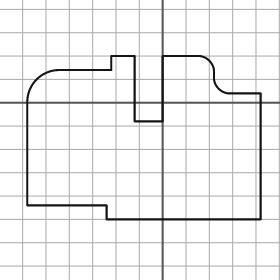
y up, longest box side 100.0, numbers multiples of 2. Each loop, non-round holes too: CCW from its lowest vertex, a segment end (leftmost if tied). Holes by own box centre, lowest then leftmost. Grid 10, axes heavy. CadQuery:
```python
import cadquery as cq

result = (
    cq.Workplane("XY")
    .moveTo(-24.0, -50.0)
    .lineTo(42.0, -50.0)
    .lineTo(42.0, 4.0)
    .lineTo(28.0, 4.0)
    .threePointArc((24.0, 6.0), (22.0, 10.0))
    .lineTo(22.0, 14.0)
    .threePointArc((20.0, 18.0), (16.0, 20.0))
    .lineTo(0.0, 20.0)
    .lineTo(0.0, -8.0)
    .lineTo(-12.0, -8.0)
    .lineTo(-12.0, 20.0)
    .lineTo(-22.0, 20.0)
    .lineTo(-22.0, 14.0)
    .lineTo(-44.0, 14.0)
    .threePointArc((-54.0, 10.0), (-58.0, 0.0))
    .lineTo(-58.0, -44.0)
    .lineTo(-24.0, -44.0)
    .close()
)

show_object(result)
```